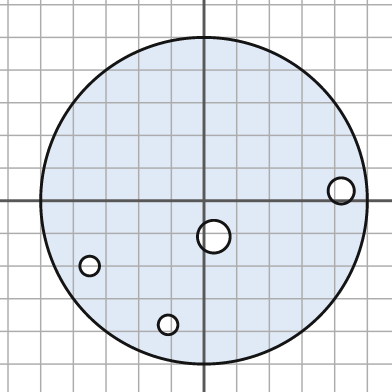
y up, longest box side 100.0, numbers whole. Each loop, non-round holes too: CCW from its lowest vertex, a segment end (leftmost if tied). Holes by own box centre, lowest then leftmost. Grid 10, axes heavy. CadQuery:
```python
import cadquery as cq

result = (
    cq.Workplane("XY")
    .moveTo(0.0, 0.0)
    .circle(50.0)
    .moveTo(-11.0, -38.0)
    .circle(3.0)
    .moveTo(-35.0, -20.0)
    .circle(3.0)
    .moveTo(3.0, -11.0)
    .circle(5.0)
    .moveTo(42.0, 3.0)
    .circle(4.0)
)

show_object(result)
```